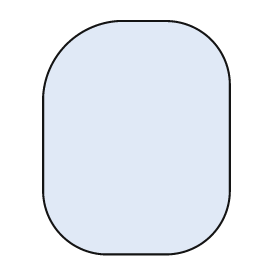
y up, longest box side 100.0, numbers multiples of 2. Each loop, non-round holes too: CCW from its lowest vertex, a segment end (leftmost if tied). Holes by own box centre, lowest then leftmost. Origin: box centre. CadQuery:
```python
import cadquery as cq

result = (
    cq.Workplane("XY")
    .moveTo(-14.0, -50.0)
    .lineTo(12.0, -50.0)
    .threePointArc((32.0, -42.0), (40.0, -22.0))
    .lineTo(40.0, 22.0)
    .threePointArc((32.0, 42.0), (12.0, 50.0))
    .lineTo(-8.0, 50.0)
    .threePointArc((-30.0, 40.0), (-40.0, 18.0))
    .lineTo(-40.0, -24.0)
    .threePointArc((-32.0, -42.0), (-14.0, -50.0))
    .close()
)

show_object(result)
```